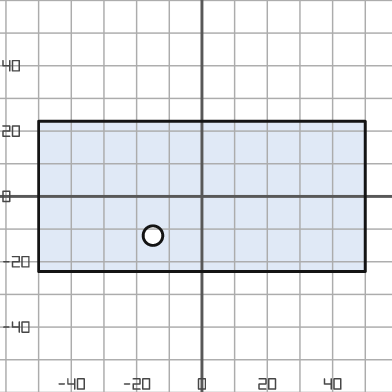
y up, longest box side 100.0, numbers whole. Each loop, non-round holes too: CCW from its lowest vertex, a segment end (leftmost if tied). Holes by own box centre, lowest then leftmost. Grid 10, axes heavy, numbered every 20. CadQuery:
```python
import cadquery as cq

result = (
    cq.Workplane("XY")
    .moveTo(-50.0, -23.0)
    .lineTo(50.0, -23.0)
    .lineTo(50.0, 23.0)
    .lineTo(-50.0, 23.0)
    .close()
    .moveTo(-15.0, -12.0)
    .circle(3.0)
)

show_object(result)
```